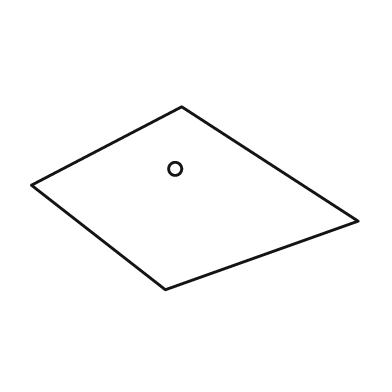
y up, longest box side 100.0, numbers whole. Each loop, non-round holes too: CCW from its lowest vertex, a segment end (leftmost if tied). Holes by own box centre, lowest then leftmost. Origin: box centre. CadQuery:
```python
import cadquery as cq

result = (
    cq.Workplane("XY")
    .moveTo(-9.0, -28.0)
    .lineTo(50.0, -7.0)
    .lineTo(-4.0, 28.0)
    .lineTo(-50.0, 4.0)
    .close()
    .moveTo(-6.0, 9.0)
    .circle(2.0)
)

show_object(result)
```